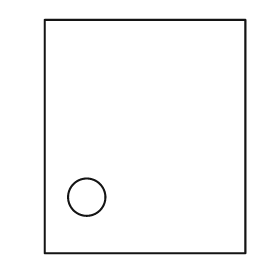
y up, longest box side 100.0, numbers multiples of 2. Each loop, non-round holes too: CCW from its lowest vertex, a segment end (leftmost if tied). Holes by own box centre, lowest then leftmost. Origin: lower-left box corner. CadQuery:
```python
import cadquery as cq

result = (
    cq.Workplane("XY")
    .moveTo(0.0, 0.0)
    .lineTo(86.0, 0.0)
    .lineTo(86.0, 100.0)
    .lineTo(0.0, 100.0)
    .close()
    .moveTo(18.0, 24.0)
    .circle(8.0)
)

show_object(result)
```